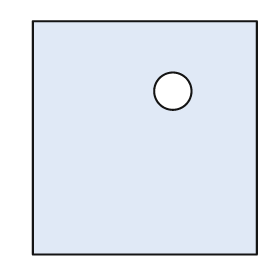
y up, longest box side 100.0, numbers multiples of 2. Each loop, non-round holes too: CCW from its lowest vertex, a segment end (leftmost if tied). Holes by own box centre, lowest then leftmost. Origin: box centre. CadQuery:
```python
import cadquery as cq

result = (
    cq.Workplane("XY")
    .moveTo(-48.0, -50.0)
    .lineTo(48.0, -50.0)
    .lineTo(48.0, 50.0)
    .lineTo(-48.0, 50.0)
    .close()
    .moveTo(12.0, 20.0)
    .circle(8.0)
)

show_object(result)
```